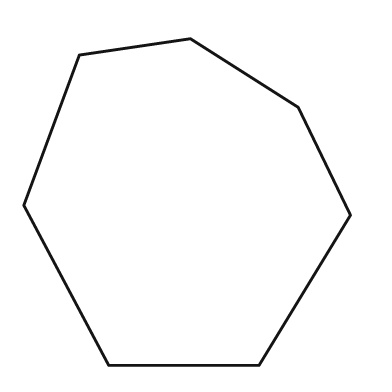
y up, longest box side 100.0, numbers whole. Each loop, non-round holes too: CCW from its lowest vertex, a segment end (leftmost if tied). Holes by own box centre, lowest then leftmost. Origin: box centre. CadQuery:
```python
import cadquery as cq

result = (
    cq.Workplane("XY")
    .moveTo(-24.0, -50.0)
    .lineTo(22.0, -50.0)
    .lineTo(50.0, -4.0)
    .lineTo(34.0, 29.0)
    .lineTo(1.0, 50.0)
    .lineTo(-33.0, 45.0)
    .lineTo(-50.0, -1.0)
    .close()
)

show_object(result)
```